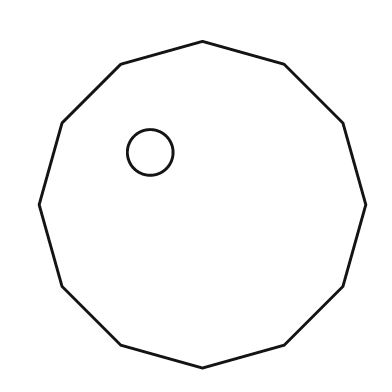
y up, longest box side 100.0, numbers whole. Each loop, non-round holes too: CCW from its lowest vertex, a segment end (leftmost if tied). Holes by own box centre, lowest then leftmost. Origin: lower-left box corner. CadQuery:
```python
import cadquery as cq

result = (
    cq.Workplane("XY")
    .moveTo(50.0, 0.0)
    .lineTo(75.0, 7.0)
    .lineTo(93.0, 25.0)
    .lineTo(100.0, 50.0)
    .lineTo(93.0, 75.0)
    .lineTo(75.0, 93.0)
    .lineTo(50.0, 100.0)
    .lineTo(25.0, 93.0)
    .lineTo(7.0, 75.0)
    .lineTo(0.0, 50.0)
    .lineTo(7.0, 25.0)
    .lineTo(25.0, 7.0)
    .close()
    .moveTo(34.0, 66.0)
    .circle(7.0)
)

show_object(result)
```